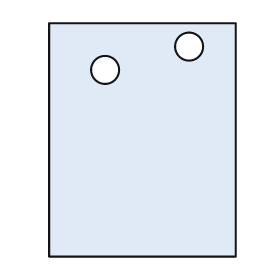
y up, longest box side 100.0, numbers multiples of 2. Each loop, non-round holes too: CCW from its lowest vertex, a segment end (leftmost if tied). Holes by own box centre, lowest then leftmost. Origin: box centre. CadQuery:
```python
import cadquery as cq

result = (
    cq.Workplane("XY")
    .moveTo(-40.0, -50.0)
    .lineTo(40.0, -50.0)
    .lineTo(40.0, 50.0)
    .lineTo(-40.0, 50.0)
    .close()
    .moveTo(-16.0, 30.0)
    .circle(6.0)
    .moveTo(20.0, 40.0)
    .circle(6.0)
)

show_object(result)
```